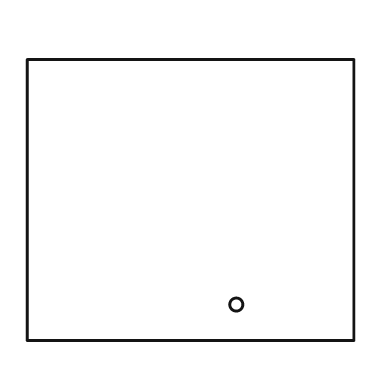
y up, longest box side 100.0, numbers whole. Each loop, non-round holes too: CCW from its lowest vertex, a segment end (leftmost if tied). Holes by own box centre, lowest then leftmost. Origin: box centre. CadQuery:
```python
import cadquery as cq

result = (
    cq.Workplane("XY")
    .moveTo(-50.0, -43.0)
    .lineTo(50.0, -43.0)
    .lineTo(50.0, 43.0)
    .lineTo(-50.0, 43.0)
    .close()
    .moveTo(14.0, -32.0)
    .circle(2.0)
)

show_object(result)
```